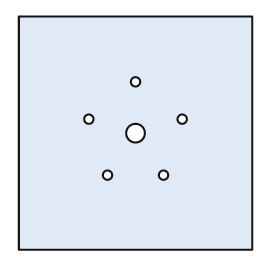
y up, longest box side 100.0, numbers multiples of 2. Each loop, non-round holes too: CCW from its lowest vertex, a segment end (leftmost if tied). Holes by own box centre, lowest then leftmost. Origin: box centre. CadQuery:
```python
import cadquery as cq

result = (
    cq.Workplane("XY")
    .moveTo(-50.0, -50.0)
    .lineTo(50.0, -50.0)
    .lineTo(50.0, 50.0)
    .lineTo(-50.0, 50.0)
    .close()
    .moveTo(-12.0, -18.0)
    .circle(2.0)
    .moveTo(12.0, -18.0)
    .circle(2.0)
    .moveTo(0.0, 0.0)
    .circle(4.0)
    .moveTo(-20.0, 6.0)
    .circle(2.0)
    .moveTo(20.0, 6.0)
    .circle(2.0)
    .moveTo(0.0, 22.0)
    .circle(2.0)
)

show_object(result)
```